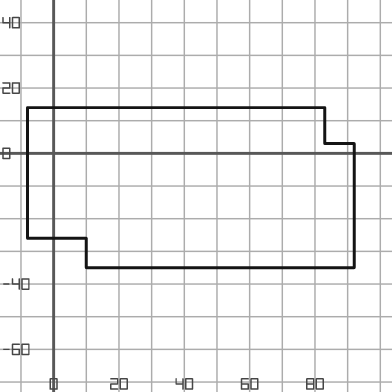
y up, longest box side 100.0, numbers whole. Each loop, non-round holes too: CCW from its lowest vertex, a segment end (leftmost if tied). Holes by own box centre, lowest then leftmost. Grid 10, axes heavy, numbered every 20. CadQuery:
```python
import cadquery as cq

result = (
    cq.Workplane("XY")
    .moveTo(10.0, -35.0)
    .lineTo(92.0, -35.0)
    .lineTo(92.0, 3.0)
    .lineTo(83.0, 3.0)
    .lineTo(83.0, 14.0)
    .lineTo(-8.0, 14.0)
    .lineTo(-8.0, -26.0)
    .lineTo(10.0, -26.0)
    .close()
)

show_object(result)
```